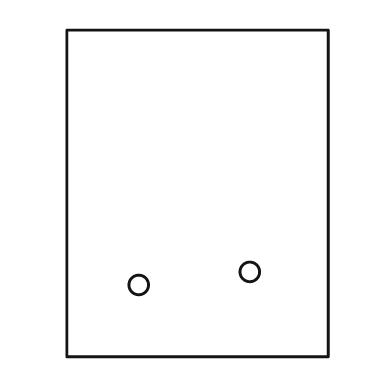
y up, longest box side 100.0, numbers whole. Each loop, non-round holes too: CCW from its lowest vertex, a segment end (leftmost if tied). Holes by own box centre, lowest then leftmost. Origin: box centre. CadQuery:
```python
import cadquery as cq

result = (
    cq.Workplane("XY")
    .moveTo(-40.0, -50.0)
    .lineTo(40.0, -50.0)
    .lineTo(40.0, 50.0)
    .lineTo(-40.0, 50.0)
    .close()
    .moveTo(-18.0, -28.0)
    .circle(3.0)
    .moveTo(16.0, -24.0)
    .circle(3.0)
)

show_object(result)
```